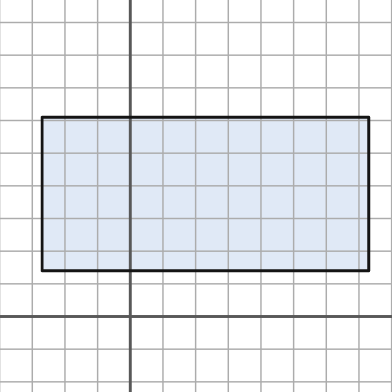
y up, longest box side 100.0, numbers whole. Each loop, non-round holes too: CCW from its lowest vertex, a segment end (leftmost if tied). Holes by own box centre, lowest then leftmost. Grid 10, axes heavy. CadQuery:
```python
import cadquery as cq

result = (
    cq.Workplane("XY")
    .moveTo(-27.0, 14.0)
    .lineTo(73.0, 14.0)
    .lineTo(73.0, 61.0)
    .lineTo(-27.0, 61.0)
    .close()
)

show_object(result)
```